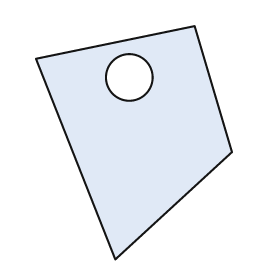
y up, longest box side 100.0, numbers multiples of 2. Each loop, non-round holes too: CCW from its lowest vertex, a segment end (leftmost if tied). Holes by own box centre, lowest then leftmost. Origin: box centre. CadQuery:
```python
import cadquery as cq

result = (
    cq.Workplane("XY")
    .moveTo(-8.0, -50.0)
    .lineTo(42.0, -4.0)
    .lineTo(26.0, 50.0)
    .lineTo(-42.0, 36.0)
    .close()
    .moveTo(-2.0, 28.0)
    .circle(10.0)
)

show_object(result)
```